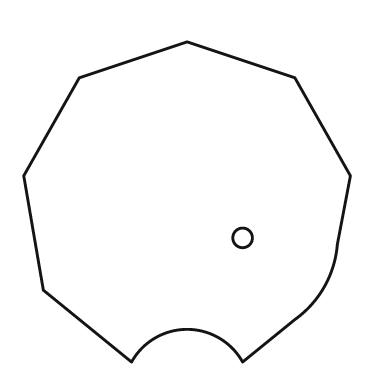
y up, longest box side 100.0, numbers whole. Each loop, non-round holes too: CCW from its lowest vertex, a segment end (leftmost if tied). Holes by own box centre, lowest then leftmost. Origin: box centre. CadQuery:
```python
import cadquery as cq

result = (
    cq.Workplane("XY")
    .moveTo(-17.0, -49.0)
    .threePointArc((0.0, -39.0), (17.0, -49.0))
    .lineTo(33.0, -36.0)
    .threePointArc((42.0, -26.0), (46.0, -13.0))
    .lineTo(50.0, 8.0)
    .lineTo(33.0, 38.0)
    .lineTo(0.0, 49.0)
    .lineTo(-33.0, 38.0)
    .lineTo(-50.0, 8.0)
    .lineTo(-44.0, -27.0)
    .close()
    .moveTo(17.0, -11.0)
    .circle(3.0)
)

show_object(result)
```